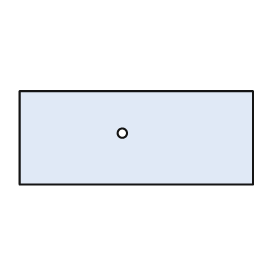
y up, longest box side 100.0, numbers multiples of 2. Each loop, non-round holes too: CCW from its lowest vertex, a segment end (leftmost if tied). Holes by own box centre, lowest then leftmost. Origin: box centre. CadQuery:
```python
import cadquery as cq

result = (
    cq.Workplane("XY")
    .moveTo(-50.0, -20.0)
    .lineTo(50.0, -20.0)
    .lineTo(50.0, 20.0)
    .lineTo(-50.0, 20.0)
    .close()
    .moveTo(-6.0, 2.0)
    .circle(2.0)
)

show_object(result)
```